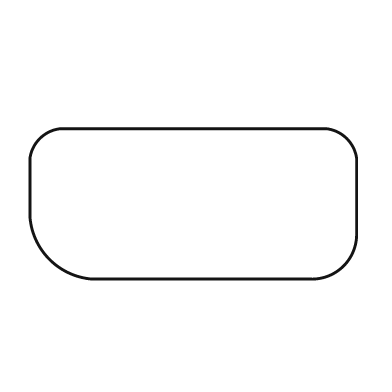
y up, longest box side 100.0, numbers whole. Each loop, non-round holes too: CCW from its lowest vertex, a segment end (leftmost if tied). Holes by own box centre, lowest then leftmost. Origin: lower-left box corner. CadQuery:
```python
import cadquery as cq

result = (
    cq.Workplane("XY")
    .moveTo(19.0, 0.0)
    .lineTo(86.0, 0.0)
    .threePointArc((96.0, 4.0), (100.0, 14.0))
    .lineTo(100.0, 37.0)
    .threePointArc((97.0, 43.0), (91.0, 46.0))
    .lineTo(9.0, 46.0)
    .threePointArc((3.0, 43.0), (0.0, 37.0))
    .lineTo(0.0, 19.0)
    .threePointArc((6.0, 6.0), (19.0, 0.0))
    .close()
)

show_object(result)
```